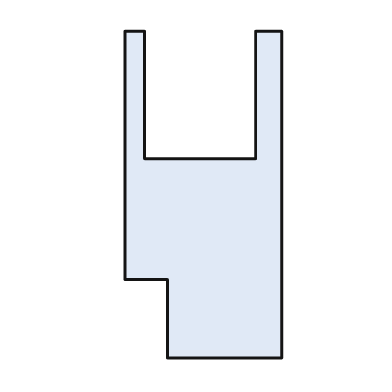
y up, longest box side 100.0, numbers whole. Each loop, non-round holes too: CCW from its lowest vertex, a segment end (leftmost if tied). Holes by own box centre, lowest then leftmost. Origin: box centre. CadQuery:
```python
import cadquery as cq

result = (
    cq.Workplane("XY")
    .moveTo(-11.0, -50.0)
    .lineTo(24.0, -50.0)
    .lineTo(24.0, 50.0)
    .lineTo(16.0, 50.0)
    .lineTo(16.0, 11.0)
    .lineTo(-18.0, 11.0)
    .lineTo(-18.0, 50.0)
    .lineTo(-24.0, 50.0)
    .lineTo(-24.0, -26.0)
    .lineTo(-11.0, -26.0)
    .close()
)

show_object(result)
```